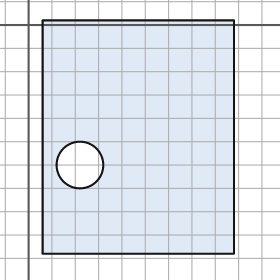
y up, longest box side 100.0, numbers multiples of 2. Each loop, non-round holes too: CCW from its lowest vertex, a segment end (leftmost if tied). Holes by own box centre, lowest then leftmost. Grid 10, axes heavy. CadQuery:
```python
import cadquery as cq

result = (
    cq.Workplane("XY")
    .moveTo(6.0, -98.0)
    .lineTo(88.0, -98.0)
    .lineTo(88.0, 2.0)
    .lineTo(6.0, 2.0)
    .close()
    .moveTo(22.0, -60.0)
    .circle(10.0)
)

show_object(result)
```